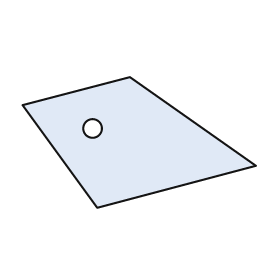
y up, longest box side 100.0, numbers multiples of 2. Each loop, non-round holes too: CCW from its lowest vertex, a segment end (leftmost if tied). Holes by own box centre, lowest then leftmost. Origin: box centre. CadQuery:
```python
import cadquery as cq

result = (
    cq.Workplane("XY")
    .moveTo(-18.0, -28.0)
    .lineTo(50.0, -10.0)
    .lineTo(-4.0, 28.0)
    .lineTo(-50.0, 16.0)
    .close()
    .moveTo(-20.0, 6.0)
    .circle(4.0)
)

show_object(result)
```